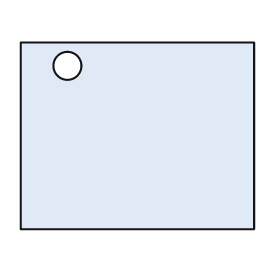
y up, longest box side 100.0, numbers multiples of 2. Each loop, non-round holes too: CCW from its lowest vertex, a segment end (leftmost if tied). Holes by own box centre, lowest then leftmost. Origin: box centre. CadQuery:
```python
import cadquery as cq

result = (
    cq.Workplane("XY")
    .moveTo(-50.0, -40.0)
    .lineTo(50.0, -40.0)
    .lineTo(50.0, 40.0)
    .lineTo(-50.0, 40.0)
    .close()
    .moveTo(-30.0, 30.0)
    .circle(6.0)
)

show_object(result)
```